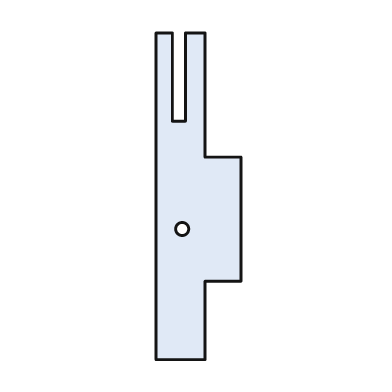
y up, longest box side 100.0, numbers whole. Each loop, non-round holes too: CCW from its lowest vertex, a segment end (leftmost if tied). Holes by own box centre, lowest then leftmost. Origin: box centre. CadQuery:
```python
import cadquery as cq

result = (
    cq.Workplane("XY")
    .moveTo(-13.0, -50.0)
    .lineTo(2.0, -50.0)
    .lineTo(2.0, -26.0)
    .lineTo(13.0, -26.0)
    .lineTo(13.0, 12.0)
    .lineTo(2.0, 12.0)
    .lineTo(2.0, 50.0)
    .lineTo(-4.0, 50.0)
    .lineTo(-4.0, 23.0)
    .lineTo(-8.0, 23.0)
    .lineTo(-8.0, 50.0)
    .lineTo(-13.0, 50.0)
    .close()
    .moveTo(-5.0, -10.0)
    .circle(2.0)
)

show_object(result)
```